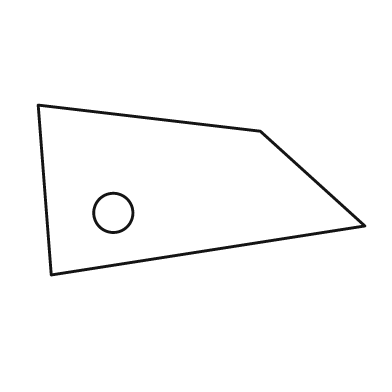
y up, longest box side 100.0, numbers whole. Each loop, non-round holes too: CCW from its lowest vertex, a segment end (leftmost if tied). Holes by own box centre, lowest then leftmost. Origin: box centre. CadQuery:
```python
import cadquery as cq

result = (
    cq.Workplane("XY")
    .moveTo(-46.0, -26.0)
    .lineTo(50.0, -11.0)
    .lineTo(18.0, 18.0)
    .lineTo(-50.0, 26.0)
    .close()
    .moveTo(-27.0, -7.0)
    .circle(6.0)
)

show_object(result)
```